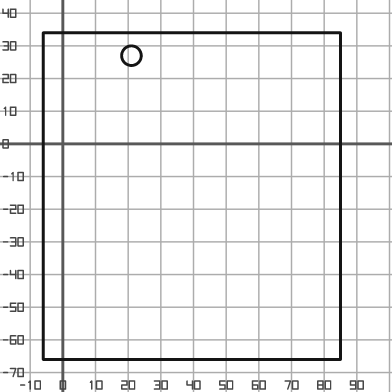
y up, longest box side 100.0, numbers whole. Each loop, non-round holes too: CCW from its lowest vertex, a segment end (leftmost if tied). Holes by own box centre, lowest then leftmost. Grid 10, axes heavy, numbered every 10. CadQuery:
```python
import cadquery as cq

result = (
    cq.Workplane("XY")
    .moveTo(-6.0, -66.0)
    .lineTo(85.0, -66.0)
    .lineTo(85.0, 34.0)
    .lineTo(-6.0, 34.0)
    .close()
    .moveTo(21.0, 27.0)
    .circle(3.0)
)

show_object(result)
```